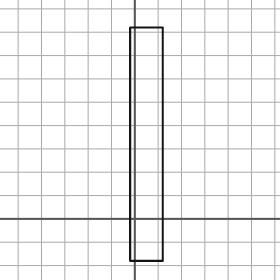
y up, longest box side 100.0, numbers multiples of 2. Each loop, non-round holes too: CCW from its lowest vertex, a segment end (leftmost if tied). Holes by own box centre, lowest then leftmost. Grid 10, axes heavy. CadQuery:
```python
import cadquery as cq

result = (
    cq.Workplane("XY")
    .moveTo(-2.0, -18.0)
    .lineTo(12.0, -18.0)
    .lineTo(12.0, 82.0)
    .lineTo(-2.0, 82.0)
    .close()
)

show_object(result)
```